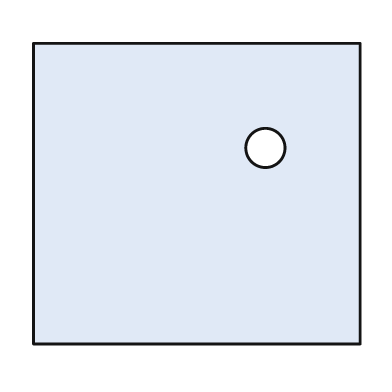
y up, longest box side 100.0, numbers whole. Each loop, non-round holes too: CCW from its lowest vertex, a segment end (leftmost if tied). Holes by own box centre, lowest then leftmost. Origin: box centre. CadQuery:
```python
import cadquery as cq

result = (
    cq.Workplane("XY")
    .moveTo(-50.0, -46.0)
    .lineTo(50.0, -46.0)
    .lineTo(50.0, 46.0)
    .lineTo(-50.0, 46.0)
    .close()
    .moveTo(21.0, 14.0)
    .circle(6.0)
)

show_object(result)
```